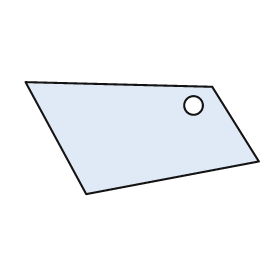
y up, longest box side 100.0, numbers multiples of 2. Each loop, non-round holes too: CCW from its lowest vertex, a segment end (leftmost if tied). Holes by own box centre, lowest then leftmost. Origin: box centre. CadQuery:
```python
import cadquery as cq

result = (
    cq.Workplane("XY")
    .moveTo(-24.0, -24.0)
    .lineTo(50.0, -10.0)
    .lineTo(30.0, 22.0)
    .lineTo(-50.0, 24.0)
    .close()
    .moveTo(22.0, 14.0)
    .circle(4.0)
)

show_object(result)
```